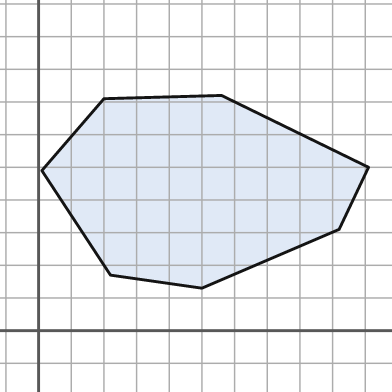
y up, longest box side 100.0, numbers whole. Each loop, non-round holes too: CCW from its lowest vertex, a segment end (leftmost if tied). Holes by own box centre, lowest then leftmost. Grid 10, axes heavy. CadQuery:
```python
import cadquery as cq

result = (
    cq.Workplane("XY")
    .moveTo(50.0, 13.0)
    .lineTo(92.0, 31.0)
    .lineTo(101.0, 50.0)
    .lineTo(56.0, 72.0)
    .lineTo(20.0, 71.0)
    .lineTo(1.0, 49.0)
    .lineTo(22.0, 17.0)
    .close()
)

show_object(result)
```